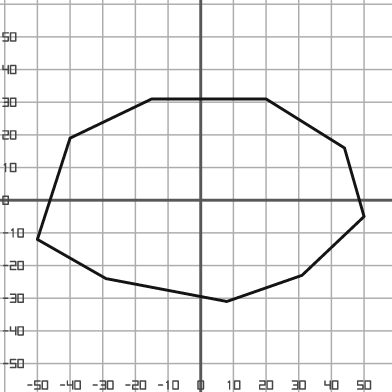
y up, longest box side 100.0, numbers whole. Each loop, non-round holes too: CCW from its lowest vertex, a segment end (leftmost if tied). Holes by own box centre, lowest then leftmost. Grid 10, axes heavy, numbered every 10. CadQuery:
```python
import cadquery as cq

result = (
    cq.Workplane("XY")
    .moveTo(8.0, -31.0)
    .lineTo(31.0, -23.0)
    .lineTo(50.0, -5.0)
    .lineTo(44.0, 16.0)
    .lineTo(20.0, 31.0)
    .lineTo(-15.0, 31.0)
    .lineTo(-40.0, 19.0)
    .lineTo(-50.0, -12.0)
    .lineTo(-29.0, -24.0)
    .close()
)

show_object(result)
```